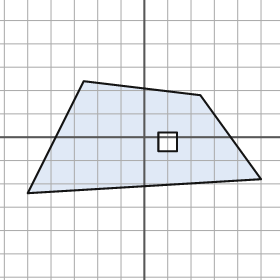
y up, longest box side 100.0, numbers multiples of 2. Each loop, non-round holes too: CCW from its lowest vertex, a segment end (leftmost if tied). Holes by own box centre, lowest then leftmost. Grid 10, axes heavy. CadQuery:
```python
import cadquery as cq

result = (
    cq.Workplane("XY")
    .moveTo(-50.0, -24.0)
    .lineTo(50.0, -18.0)
    .lineTo(24.0, 18.0)
    .lineTo(-26.0, 24.0)
    .close()
    .moveTo(6.0, -6.0)
    .lineTo(14.0, -6.0)
    .lineTo(14.0, 2.0)
    .lineTo(6.0, 2.0)
    .close()
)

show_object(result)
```